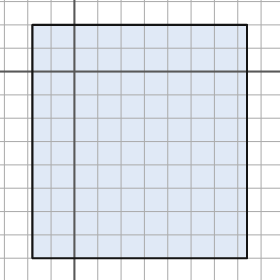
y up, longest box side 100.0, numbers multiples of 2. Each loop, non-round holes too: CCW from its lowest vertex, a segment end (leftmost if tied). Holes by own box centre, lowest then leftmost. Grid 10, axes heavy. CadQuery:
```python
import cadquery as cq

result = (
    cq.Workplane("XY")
    .moveTo(-18.0, -80.0)
    .lineTo(74.0, -80.0)
    .lineTo(74.0, 20.0)
    .lineTo(-18.0, 20.0)
    .close()
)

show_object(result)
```